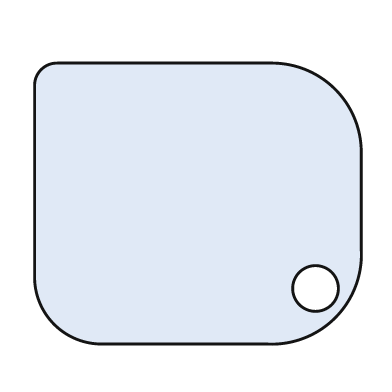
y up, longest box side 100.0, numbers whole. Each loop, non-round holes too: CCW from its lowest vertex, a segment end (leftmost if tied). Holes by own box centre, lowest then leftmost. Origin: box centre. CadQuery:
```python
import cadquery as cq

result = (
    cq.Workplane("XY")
    .moveTo(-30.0, -43.0)
    .lineTo(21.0, -43.0)
    .threePointArc((42.0, -35.0), (50.0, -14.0))
    .lineTo(50.0, 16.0)
    .threePointArc((42.0, 35.0), (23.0, 43.0))
    .lineTo(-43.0, 43.0)
    .threePointArc((-48.0, 41.0), (-50.0, 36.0))
    .lineTo(-50.0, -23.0)
    .threePointArc((-44.0, -37.0), (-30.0, -43.0))
    .close()
    .moveTo(36.0, -26.0)
    .circle(7.0)
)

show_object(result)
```